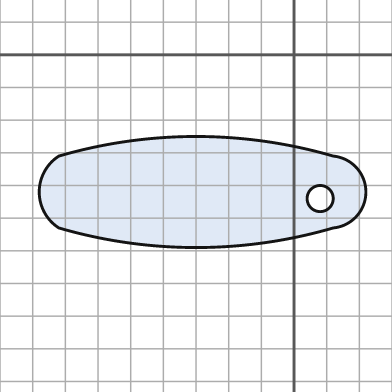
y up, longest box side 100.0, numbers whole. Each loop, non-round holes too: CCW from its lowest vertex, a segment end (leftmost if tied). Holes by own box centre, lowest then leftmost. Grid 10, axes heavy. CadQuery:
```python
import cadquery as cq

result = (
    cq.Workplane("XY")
    .moveTo(-72.0, -53.0)
    .threePointArc((-30.0, -59.0), (12.0, -53.0))
    .threePointArc((22.0, -42.0), (12.0, -31.0))
    .threePointArc((-30.0, -25.0), (-72.0, -31.0))
    .threePointArc((-78.0, -42.0), (-72.0, -53.0))
    .close()
    .moveTo(8.0, -44.0)
    .circle(4.0)
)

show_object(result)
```